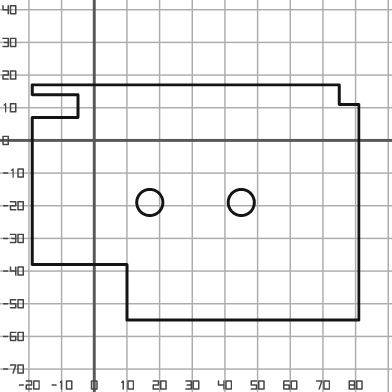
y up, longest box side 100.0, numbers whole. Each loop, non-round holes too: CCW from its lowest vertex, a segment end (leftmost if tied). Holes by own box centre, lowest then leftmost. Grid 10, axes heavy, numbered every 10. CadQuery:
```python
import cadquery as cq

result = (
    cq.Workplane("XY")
    .moveTo(10.0, -55.0)
    .lineTo(81.0, -55.0)
    .lineTo(81.0, 11.0)
    .lineTo(75.0, 11.0)
    .lineTo(75.0, 17.0)
    .lineTo(-19.0, 17.0)
    .lineTo(-19.0, 14.0)
    .lineTo(-5.0, 14.0)
    .lineTo(-5.0, 7.0)
    .lineTo(-19.0, 7.0)
    .lineTo(-19.0, -38.0)
    .lineTo(10.0, -38.0)
    .close()
    .moveTo(17.0, -19.0)
    .circle(4.0)
    .moveTo(45.0, -19.0)
    .circle(4.0)
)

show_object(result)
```